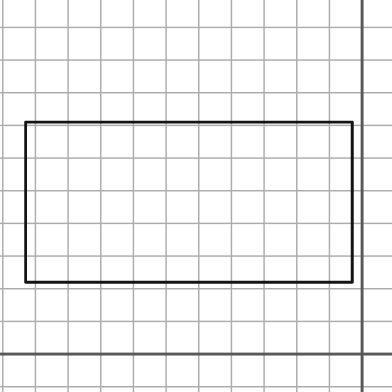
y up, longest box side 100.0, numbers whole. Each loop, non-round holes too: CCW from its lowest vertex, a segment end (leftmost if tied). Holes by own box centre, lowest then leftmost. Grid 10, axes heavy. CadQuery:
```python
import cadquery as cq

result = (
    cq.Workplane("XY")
    .moveTo(-103.0, 22.0)
    .lineTo(-3.0, 22.0)
    .lineTo(-3.0, 71.0)
    .lineTo(-103.0, 71.0)
    .close()
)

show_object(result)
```